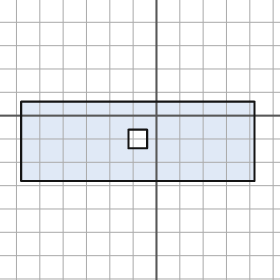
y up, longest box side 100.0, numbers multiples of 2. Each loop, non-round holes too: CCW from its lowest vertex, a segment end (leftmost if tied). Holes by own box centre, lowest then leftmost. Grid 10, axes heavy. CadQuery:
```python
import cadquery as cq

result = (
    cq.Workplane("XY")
    .moveTo(-58.0, -28.0)
    .lineTo(42.0, -28.0)
    .lineTo(42.0, 6.0)
    .lineTo(-58.0, 6.0)
    .close()
    .moveTo(-12.0, -14.0)
    .lineTo(-4.0, -14.0)
    .lineTo(-4.0, -6.0)
    .lineTo(-12.0, -6.0)
    .close()
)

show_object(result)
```